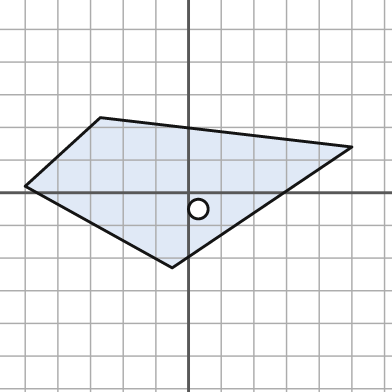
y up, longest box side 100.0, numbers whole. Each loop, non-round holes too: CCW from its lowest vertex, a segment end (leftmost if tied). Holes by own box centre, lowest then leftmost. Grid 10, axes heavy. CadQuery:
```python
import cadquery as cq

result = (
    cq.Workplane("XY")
    .moveTo(-5.0, -23.0)
    .lineTo(50.0, 14.0)
    .lineTo(-27.0, 23.0)
    .lineTo(-50.0, 2.0)
    .close()
    .moveTo(3.0, -5.0)
    .circle(3.0)
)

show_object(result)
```